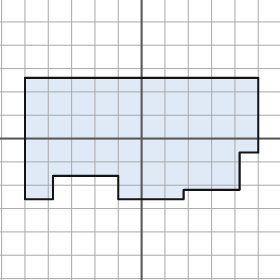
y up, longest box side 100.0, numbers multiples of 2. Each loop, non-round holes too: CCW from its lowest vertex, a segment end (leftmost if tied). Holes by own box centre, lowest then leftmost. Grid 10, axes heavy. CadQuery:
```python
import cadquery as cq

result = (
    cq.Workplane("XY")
    .moveTo(-50.0, -26.0)
    .lineTo(-38.0, -26.0)
    .lineTo(-38.0, -16.0)
    .lineTo(-10.0, -16.0)
    .lineTo(-10.0, -26.0)
    .lineTo(18.0, -26.0)
    .lineTo(18.0, -22.0)
    .lineTo(42.0, -22.0)
    .lineTo(42.0, -6.0)
    .lineTo(50.0, -6.0)
    .lineTo(50.0, 26.0)
    .lineTo(-50.0, 26.0)
    .close()
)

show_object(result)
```